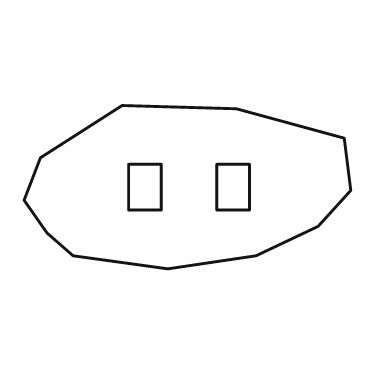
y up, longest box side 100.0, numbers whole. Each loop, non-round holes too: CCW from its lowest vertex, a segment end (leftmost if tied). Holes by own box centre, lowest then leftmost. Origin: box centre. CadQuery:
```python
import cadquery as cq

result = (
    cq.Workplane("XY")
    .moveTo(-6.0, -25.0)
    .lineTo(21.0, -21.0)
    .lineTo(40.0, -12.0)
    .lineTo(50.0, -1.0)
    .lineTo(48.0, 15.0)
    .lineTo(15.0, 24.0)
    .lineTo(-20.0, 25.0)
    .lineTo(-45.0, 9.0)
    .lineTo(-50.0, -4.0)
    .lineTo(-43.0, -14.0)
    .lineTo(-35.0, -21.0)
    .close()
    .moveTo(-18.0, -7.0)
    .lineTo(-8.0, -7.0)
    .lineTo(-8.0, 7.0)
    .lineTo(-18.0, 7.0)
    .close()
    .moveTo(9.0, -7.0)
    .lineTo(19.0, -7.0)
    .lineTo(19.0, 7.0)
    .lineTo(9.0, 7.0)
    .close()
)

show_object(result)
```